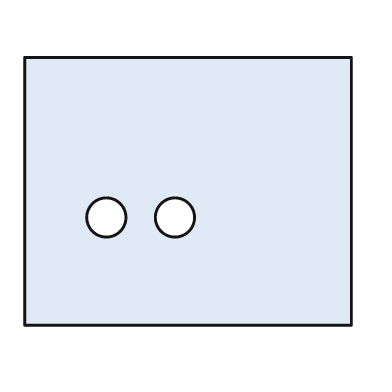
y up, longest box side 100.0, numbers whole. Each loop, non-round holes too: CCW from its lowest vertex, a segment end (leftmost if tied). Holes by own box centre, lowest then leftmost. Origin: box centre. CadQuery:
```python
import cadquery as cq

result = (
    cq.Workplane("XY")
    .moveTo(-50.0, -41.0)
    .lineTo(50.0, -41.0)
    .lineTo(50.0, 41.0)
    .lineTo(-50.0, 41.0)
    .close()
    .moveTo(-25.0, -8.0)
    .circle(6.0)
    .moveTo(-4.0, -8.0)
    .circle(6.0)
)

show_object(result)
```